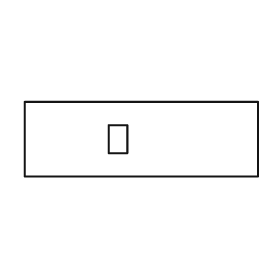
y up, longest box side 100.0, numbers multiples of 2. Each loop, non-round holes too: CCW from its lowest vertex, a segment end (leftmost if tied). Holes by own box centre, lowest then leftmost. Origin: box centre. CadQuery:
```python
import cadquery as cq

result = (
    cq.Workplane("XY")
    .moveTo(-50.0, -16.0)
    .lineTo(50.0, -16.0)
    .lineTo(50.0, 16.0)
    .lineTo(-50.0, 16.0)
    .close()
    .moveTo(-14.0, -6.0)
    .lineTo(-6.0, -6.0)
    .lineTo(-6.0, 6.0)
    .lineTo(-14.0, 6.0)
    .close()
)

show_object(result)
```